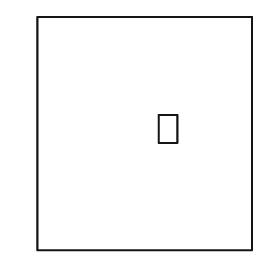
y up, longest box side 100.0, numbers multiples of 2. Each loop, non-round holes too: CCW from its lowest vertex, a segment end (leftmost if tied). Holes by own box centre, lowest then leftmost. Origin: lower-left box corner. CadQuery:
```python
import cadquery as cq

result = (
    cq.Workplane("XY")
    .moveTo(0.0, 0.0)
    .lineTo(92.0, 0.0)
    .lineTo(92.0, 100.0)
    .lineTo(0.0, 100.0)
    .close()
    .moveTo(52.0, 46.0)
    .lineTo(60.0, 46.0)
    .lineTo(60.0, 58.0)
    .lineTo(52.0, 58.0)
    .close()
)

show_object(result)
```